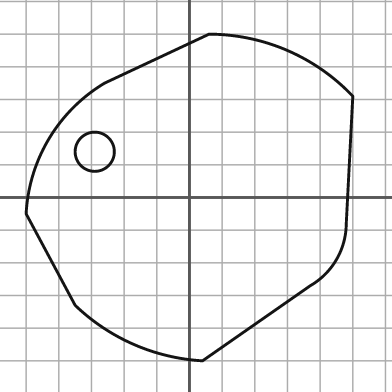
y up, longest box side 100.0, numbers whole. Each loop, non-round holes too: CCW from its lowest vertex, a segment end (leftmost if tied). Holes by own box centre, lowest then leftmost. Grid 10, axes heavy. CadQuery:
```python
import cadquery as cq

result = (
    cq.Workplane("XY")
    .moveTo(4.0, -50.0)
    .lineTo(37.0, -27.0)
    .threePointArc((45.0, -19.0), (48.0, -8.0))
    .lineTo(50.0, 31.0)
    .threePointArc((30.0, 45.0), (6.0, 50.0))
    .lineTo(-26.0, 35.0)
    .threePointArc((-43.0, 18.0), (-50.0, -5.0))
    .lineTo(-35.0, -33.0)
    .threePointArc((-17.0, -45.0), (4.0, -50.0))
    .close()
    .moveTo(-29.0, 14.0)
    .circle(6.0)
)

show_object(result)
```